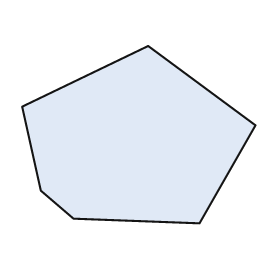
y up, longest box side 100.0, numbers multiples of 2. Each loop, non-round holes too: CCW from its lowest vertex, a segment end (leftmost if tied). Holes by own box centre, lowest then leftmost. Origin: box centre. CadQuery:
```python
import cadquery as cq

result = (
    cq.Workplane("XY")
    .moveTo(26.0, -38.0)
    .lineTo(50.0, 4.0)
    .lineTo(4.0, 38.0)
    .lineTo(-50.0, 12.0)
    .lineTo(-42.0, -24.0)
    .lineTo(-28.0, -36.0)
    .close()
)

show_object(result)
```